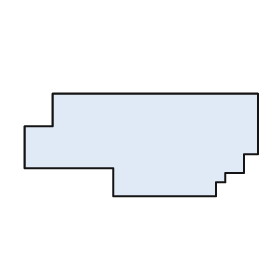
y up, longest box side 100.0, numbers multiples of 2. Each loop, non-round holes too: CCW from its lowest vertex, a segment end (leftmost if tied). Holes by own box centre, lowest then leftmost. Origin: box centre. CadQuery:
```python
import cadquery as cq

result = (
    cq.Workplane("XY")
    .moveTo(-12.0, -22.0)
    .lineTo(32.0, -22.0)
    .lineTo(32.0, -16.0)
    .lineTo(36.0, -16.0)
    .lineTo(36.0, -12.0)
    .lineTo(44.0, -12.0)
    .lineTo(44.0, -4.0)
    .lineTo(50.0, -4.0)
    .lineTo(50.0, 22.0)
    .lineTo(-38.0, 22.0)
    .lineTo(-38.0, 8.0)
    .lineTo(-50.0, 8.0)
    .lineTo(-50.0, -10.0)
    .lineTo(-12.0, -10.0)
    .close()
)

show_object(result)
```